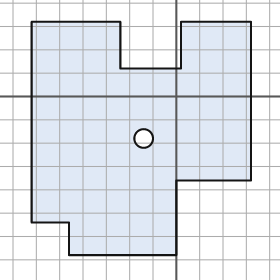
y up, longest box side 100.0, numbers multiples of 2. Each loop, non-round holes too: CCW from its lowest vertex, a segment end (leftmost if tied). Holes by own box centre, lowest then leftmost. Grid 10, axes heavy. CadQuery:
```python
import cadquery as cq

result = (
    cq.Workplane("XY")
    .moveTo(-46.0, -68.0)
    .lineTo(0.0, -68.0)
    .lineTo(0.0, -36.0)
    .lineTo(32.0, -36.0)
    .lineTo(32.0, 32.0)
    .lineTo(2.0, 32.0)
    .lineTo(2.0, 12.0)
    .lineTo(-24.0, 12.0)
    .lineTo(-24.0, 32.0)
    .lineTo(-62.0, 32.0)
    .lineTo(-62.0, -54.0)
    .lineTo(-46.0, -54.0)
    .close()
    .moveTo(-14.0, -18.0)
    .circle(4.0)
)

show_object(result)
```